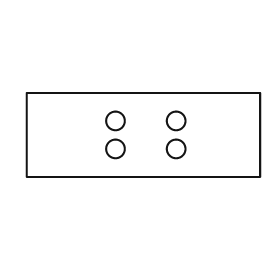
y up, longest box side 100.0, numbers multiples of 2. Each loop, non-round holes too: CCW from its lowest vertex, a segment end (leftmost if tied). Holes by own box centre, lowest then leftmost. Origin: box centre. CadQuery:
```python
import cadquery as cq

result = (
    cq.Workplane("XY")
    .moveTo(-50.0, -18.0)
    .lineTo(50.0, -18.0)
    .lineTo(50.0, 18.0)
    .lineTo(-50.0, 18.0)
    .close()
    .moveTo(-12.0, -6.0)
    .circle(4.0)
    .moveTo(14.0, -6.0)
    .circle(4.0)
    .moveTo(-12.0, 6.0)
    .circle(4.0)
    .moveTo(14.0, 6.0)
    .circle(4.0)
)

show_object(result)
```